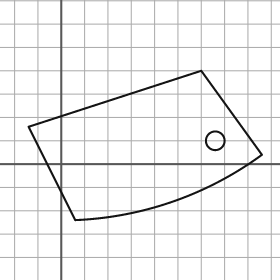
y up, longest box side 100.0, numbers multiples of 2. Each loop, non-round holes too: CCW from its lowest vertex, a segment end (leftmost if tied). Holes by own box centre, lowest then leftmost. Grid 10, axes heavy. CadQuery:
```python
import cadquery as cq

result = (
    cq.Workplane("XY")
    .moveTo(6.0, -24.0)
    .threePointArc((48.0, -16.0), (86.0, 4.0))
    .lineTo(60.0, 40.0)
    .lineTo(-14.0, 16.0)
    .close()
    .moveTo(66.0, 10.0)
    .circle(4.0)
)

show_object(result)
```